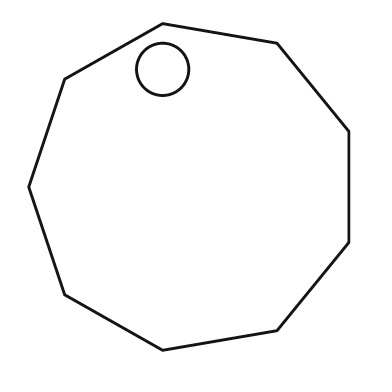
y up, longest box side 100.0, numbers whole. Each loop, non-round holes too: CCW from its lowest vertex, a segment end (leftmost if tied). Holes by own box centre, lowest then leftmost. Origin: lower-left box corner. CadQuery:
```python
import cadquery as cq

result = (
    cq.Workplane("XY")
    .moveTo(41.0, 0.0)
    .lineTo(76.0, 6.0)
    .lineTo(98.0, 33.0)
    .lineTo(98.0, 67.0)
    .lineTo(76.0, 94.0)
    .lineTo(41.0, 100.0)
    .lineTo(11.0, 83.0)
    .lineTo(0.0, 50.0)
    .lineTo(11.0, 17.0)
    .close()
    .moveTo(41.0, 86.0)
    .circle(8.0)
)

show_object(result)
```